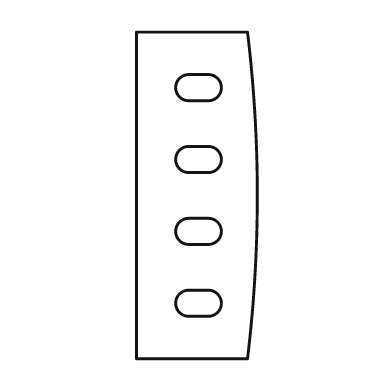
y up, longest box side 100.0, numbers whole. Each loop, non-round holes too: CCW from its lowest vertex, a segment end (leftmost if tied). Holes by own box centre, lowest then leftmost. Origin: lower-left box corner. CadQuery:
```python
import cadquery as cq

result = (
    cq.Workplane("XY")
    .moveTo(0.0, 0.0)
    .lineTo(34.0, 0.0)
    .threePointArc((37.0, 50.0), (34.0, 100.0))
    .lineTo(0.0, 100.0)
    .close()
    .moveTo(16.0, 13.0)
    .lineTo(22.0, 13.0)
    .threePointArc((26.0, 17.0), (22.0, 21.0))
    .lineTo(16.0, 21.0)
    .threePointArc((12.0, 17.0), (16.0, 13.0))
    .close()
    .moveTo(16.0, 35.0)
    .lineTo(22.0, 35.0)
    .threePointArc((26.0, 39.0), (22.0, 43.0))
    .lineTo(16.0, 43.0)
    .threePointArc((12.0, 39.0), (16.0, 35.0))
    .close()
    .moveTo(16.0, 57.0)
    .lineTo(22.0, 57.0)
    .threePointArc((26.0, 61.0), (22.0, 65.0))
    .lineTo(16.0, 65.0)
    .threePointArc((12.0, 61.0), (16.0, 57.0))
    .close()
    .moveTo(16.0, 79.0)
    .lineTo(22.0, 79.0)
    .threePointArc((26.0, 83.0), (22.0, 87.0))
    .lineTo(16.0, 87.0)
    .threePointArc((12.0, 83.0), (16.0, 79.0))
    .close()
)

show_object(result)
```